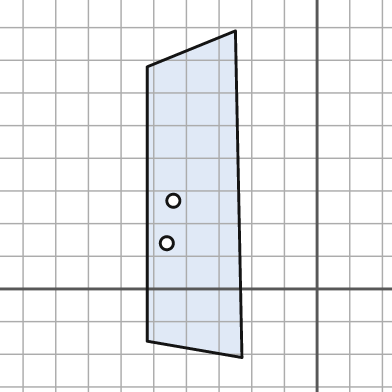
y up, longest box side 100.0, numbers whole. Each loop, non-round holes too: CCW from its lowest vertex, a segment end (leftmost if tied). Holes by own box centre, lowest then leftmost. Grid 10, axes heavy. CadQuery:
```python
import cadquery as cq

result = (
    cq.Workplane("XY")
    .moveTo(-23.0, -21.0)
    .lineTo(-25.0, 79.0)
    .lineTo(-52.0, 68.0)
    .lineTo(-52.0, -16.0)
    .close()
    .moveTo(-46.0, 14.0)
    .circle(2.0)
    .moveTo(-44.0, 27.0)
    .circle(2.0)
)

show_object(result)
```